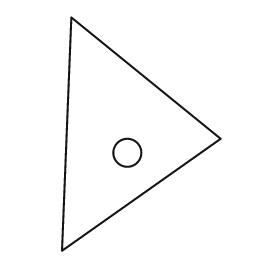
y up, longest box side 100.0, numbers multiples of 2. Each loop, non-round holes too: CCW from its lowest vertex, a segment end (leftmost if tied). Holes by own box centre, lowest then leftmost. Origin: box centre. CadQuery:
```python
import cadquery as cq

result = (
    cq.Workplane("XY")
    .moveTo(-34.0, -50.0)
    .lineTo(34.0, -2.0)
    .lineTo(-30.0, 50.0)
    .close()
    .moveTo(-6.0, -8.0)
    .circle(6.0)
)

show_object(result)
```